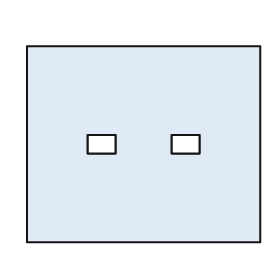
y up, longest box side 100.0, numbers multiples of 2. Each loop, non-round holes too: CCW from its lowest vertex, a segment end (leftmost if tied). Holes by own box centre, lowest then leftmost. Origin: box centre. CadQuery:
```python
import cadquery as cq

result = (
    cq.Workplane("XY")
    .moveTo(-50.0, -42.0)
    .lineTo(50.0, -42.0)
    .lineTo(50.0, 42.0)
    .lineTo(-50.0, 42.0)
    .close()
    .moveTo(-24.0, -4.0)
    .lineTo(-12.0, -4.0)
    .lineTo(-12.0, 4.0)
    .lineTo(-24.0, 4.0)
    .close()
    .moveTo(12.0, -4.0)
    .lineTo(24.0, -4.0)
    .lineTo(24.0, 4.0)
    .lineTo(12.0, 4.0)
    .close()
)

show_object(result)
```